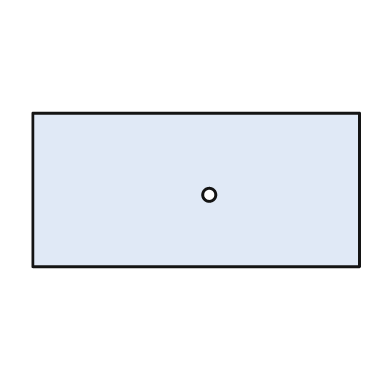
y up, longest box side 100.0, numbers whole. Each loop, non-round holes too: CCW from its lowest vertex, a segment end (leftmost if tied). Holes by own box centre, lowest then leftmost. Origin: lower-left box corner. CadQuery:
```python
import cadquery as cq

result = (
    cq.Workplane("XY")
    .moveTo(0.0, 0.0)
    .lineTo(100.0, 0.0)
    .lineTo(100.0, 47.0)
    .lineTo(0.0, 47.0)
    .close()
    .moveTo(54.0, 22.0)
    .circle(2.0)
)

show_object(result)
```